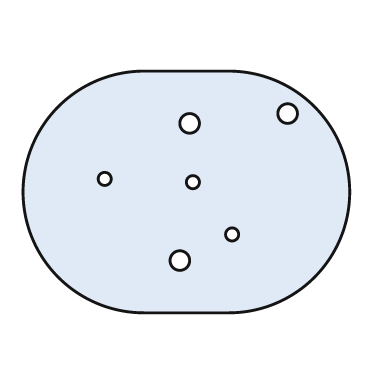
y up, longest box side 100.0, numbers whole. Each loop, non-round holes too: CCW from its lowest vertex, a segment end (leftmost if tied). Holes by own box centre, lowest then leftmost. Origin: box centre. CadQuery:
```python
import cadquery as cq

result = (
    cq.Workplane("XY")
    .moveTo(-13.0, -37.0)
    .lineTo(13.0, -37.0)
    .threePointArc((50.0, 0.0), (13.0, 37.0))
    .lineTo(-13.0, 37.0)
    .threePointArc((-50.0, 0.0), (-13.0, -37.0))
    .close()
    .moveTo(-2.0, -21.0)
    .circle(3.0)
    .moveTo(14.0, -13.0)
    .circle(2.0)
    .moveTo(2.0, 3.0)
    .circle(2.0)
    .moveTo(-25.0, 4.0)
    .circle(2.0)
    .moveTo(1.0, 21.0)
    .circle(3.0)
    .moveTo(31.0, 24.0)
    .circle(3.0)
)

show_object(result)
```